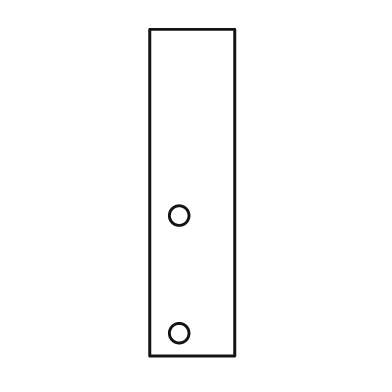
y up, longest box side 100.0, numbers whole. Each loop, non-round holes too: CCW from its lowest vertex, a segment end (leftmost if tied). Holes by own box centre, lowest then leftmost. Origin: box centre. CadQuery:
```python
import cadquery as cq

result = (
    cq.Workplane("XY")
    .moveTo(-13.0, -50.0)
    .lineTo(13.0, -50.0)
    .lineTo(13.0, 50.0)
    .lineTo(-13.0, 50.0)
    .close()
    .moveTo(-4.0, -43.0)
    .circle(3.0)
    .moveTo(-4.0, -7.0)
    .circle(3.0)
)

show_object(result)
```